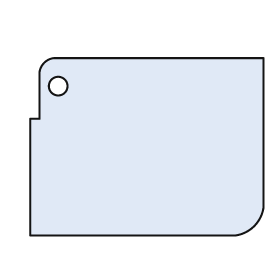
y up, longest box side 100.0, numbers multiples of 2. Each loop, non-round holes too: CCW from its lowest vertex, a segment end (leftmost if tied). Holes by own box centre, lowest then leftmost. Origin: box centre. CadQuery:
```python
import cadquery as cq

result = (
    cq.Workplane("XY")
    .moveTo(-50.0, -38.0)
    .lineTo(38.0, -38.0)
    .threePointArc((46.0, -34.0), (50.0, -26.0))
    .lineTo(50.0, 38.0)
    .lineTo(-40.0, 38.0)
    .threePointArc((-44.0, 36.0), (-46.0, 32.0))
    .lineTo(-46.0, 12.0)
    .lineTo(-50.0, 12.0)
    .close()
    .moveTo(-38.0, 26.0)
    .circle(4.0)
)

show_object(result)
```